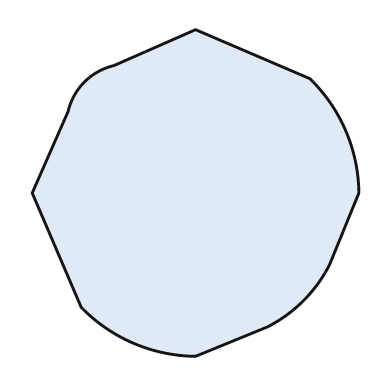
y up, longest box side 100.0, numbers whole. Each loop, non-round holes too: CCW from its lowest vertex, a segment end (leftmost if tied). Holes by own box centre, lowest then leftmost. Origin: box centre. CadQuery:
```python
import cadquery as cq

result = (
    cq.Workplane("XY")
    .moveTo(0.0, -50.0)
    .lineTo(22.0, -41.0)
    .threePointArc((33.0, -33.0), (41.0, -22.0))
    .lineTo(50.0, 0.0)
    .threePointArc((46.0, 19.0), (35.0, 35.0))
    .lineTo(0.0, 50.0)
    .lineTo(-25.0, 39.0)
    .threePointArc((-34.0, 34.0), (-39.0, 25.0))
    .lineTo(-50.0, 0.0)
    .lineTo(-35.0, -35.0)
    .threePointArc((-19.0, -46.0), (0.0, -50.0))
    .close()
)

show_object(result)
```